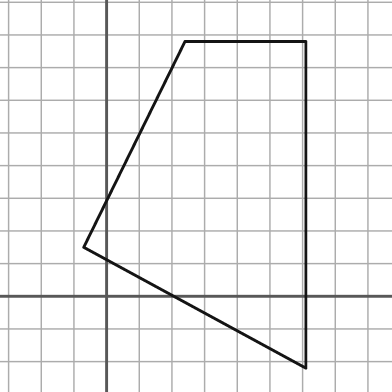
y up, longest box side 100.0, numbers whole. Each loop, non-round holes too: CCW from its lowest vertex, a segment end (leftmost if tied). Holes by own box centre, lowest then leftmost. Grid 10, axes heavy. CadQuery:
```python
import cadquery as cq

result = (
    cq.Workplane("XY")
    .moveTo(61.0, -22.0)
    .lineTo(61.0, 78.0)
    .lineTo(24.0, 78.0)
    .lineTo(-7.0, 15.0)
    .close()
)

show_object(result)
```